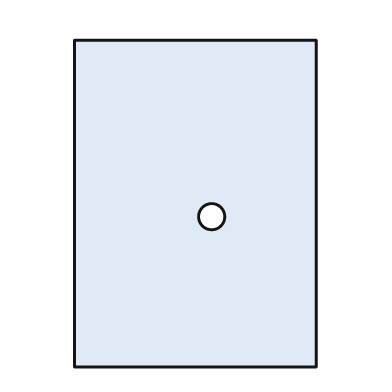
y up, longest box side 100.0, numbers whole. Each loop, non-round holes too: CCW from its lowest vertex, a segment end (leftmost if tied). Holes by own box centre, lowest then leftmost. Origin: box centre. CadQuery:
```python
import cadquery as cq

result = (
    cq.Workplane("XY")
    .moveTo(-37.0, -50.0)
    .lineTo(37.0, -50.0)
    .lineTo(37.0, 50.0)
    .lineTo(-37.0, 50.0)
    .close()
    .moveTo(5.0, -4.0)
    .circle(4.0)
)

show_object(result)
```